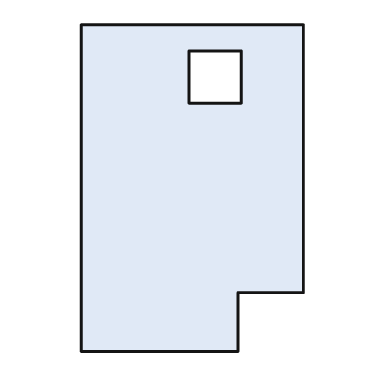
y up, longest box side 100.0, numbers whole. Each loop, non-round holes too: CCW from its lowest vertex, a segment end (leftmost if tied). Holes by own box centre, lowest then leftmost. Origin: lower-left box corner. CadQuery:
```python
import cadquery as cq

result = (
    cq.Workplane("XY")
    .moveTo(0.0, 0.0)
    .lineTo(48.0, 0.0)
    .lineTo(48.0, 18.0)
    .lineTo(68.0, 18.0)
    .lineTo(68.0, 100.0)
    .lineTo(0.0, 100.0)
    .close()
    .moveTo(33.0, 76.0)
    .lineTo(49.0, 76.0)
    .lineTo(49.0, 92.0)
    .lineTo(33.0, 92.0)
    .close()
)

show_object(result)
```